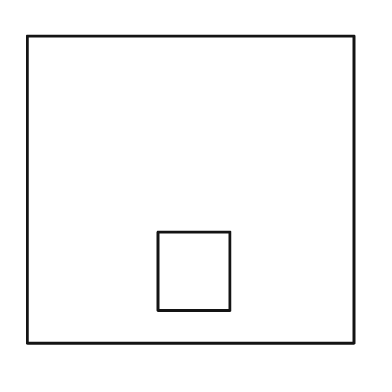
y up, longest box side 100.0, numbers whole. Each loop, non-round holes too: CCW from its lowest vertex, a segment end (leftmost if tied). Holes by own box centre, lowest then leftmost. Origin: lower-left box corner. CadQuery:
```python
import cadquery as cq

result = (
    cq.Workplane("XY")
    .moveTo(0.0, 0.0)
    .lineTo(100.0, 0.0)
    .lineTo(100.0, 94.0)
    .lineTo(0.0, 94.0)
    .close()
    .moveTo(40.0, 10.0)
    .lineTo(62.0, 10.0)
    .lineTo(62.0, 34.0)
    .lineTo(40.0, 34.0)
    .close()
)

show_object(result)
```